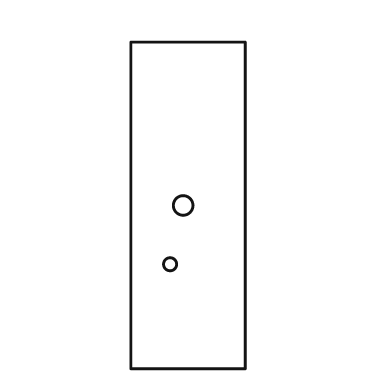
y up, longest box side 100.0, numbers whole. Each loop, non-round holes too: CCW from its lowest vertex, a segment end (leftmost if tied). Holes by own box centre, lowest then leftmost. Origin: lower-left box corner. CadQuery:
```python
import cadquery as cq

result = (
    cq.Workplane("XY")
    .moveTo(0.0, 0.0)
    .lineTo(35.0, 0.0)
    .lineTo(35.0, 100.0)
    .lineTo(0.0, 100.0)
    .close()
    .moveTo(12.0, 32.0)
    .circle(2.0)
    .moveTo(16.0, 50.0)
    .circle(3.0)
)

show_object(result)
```